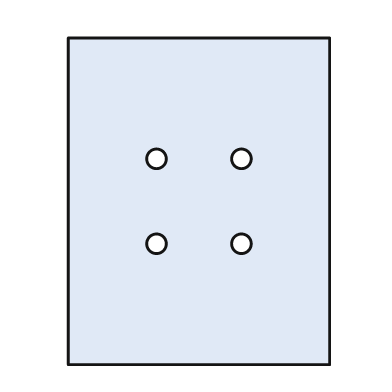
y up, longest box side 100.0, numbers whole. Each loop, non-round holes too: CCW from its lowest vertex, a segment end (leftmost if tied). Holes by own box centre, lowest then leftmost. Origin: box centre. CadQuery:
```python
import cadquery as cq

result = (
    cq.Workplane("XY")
    .moveTo(-40.0, -50.0)
    .lineTo(40.0, -50.0)
    .lineTo(40.0, 50.0)
    .lineTo(-40.0, 50.0)
    .close()
    .moveTo(-13.0, -13.0)
    .circle(3.0)
    .moveTo(13.0, -13.0)
    .circle(3.0)
    .moveTo(-13.0, 13.0)
    .circle(3.0)
    .moveTo(13.0, 13.0)
    .circle(3.0)
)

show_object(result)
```